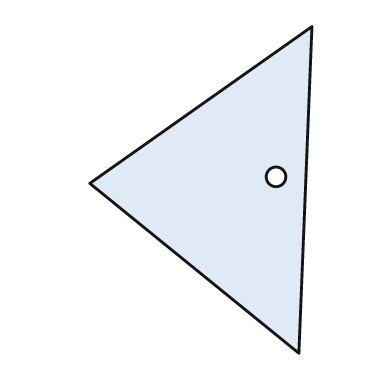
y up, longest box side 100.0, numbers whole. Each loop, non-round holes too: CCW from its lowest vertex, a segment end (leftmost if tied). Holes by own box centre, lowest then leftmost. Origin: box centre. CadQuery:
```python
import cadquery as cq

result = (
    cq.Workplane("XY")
    .moveTo(30.0, -50.0)
    .lineTo(34.0, 50.0)
    .lineTo(-34.0, 2.0)
    .close()
    .moveTo(23.0, 4.0)
    .circle(3.0)
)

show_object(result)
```